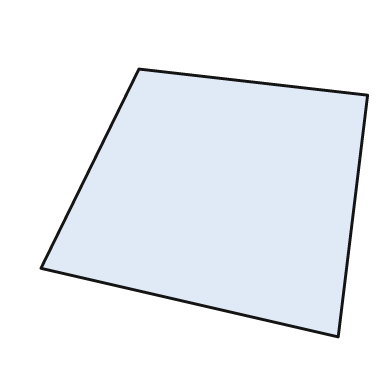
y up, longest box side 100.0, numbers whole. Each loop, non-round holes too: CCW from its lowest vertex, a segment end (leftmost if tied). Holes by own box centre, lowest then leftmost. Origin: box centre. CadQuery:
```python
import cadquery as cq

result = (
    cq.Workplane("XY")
    .moveTo(41.0, -41.0)
    .lineTo(50.0, 33.0)
    .lineTo(-20.0, 41.0)
    .lineTo(-50.0, -20.0)
    .close()
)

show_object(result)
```